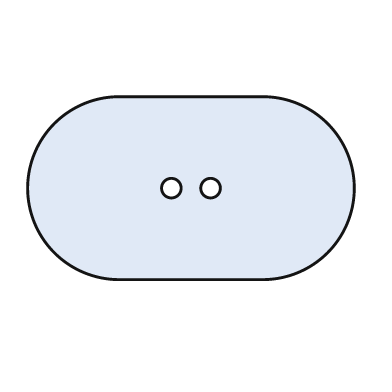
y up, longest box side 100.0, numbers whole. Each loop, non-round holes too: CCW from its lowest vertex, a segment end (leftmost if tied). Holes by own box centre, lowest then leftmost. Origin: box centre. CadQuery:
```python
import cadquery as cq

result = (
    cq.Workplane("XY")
    .moveTo(-22.0, -28.0)
    .lineTo(22.0, -28.0)
    .threePointArc((50.0, 0.0), (22.0, 28.0))
    .lineTo(-22.0, 28.0)
    .threePointArc((-50.0, 0.0), (-22.0, -28.0))
    .close()
    .moveTo(-6.0, 0.0)
    .circle(3.0)
    .moveTo(6.0, 0.0)
    .circle(3.0)
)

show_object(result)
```